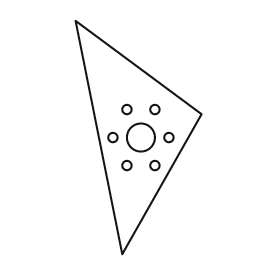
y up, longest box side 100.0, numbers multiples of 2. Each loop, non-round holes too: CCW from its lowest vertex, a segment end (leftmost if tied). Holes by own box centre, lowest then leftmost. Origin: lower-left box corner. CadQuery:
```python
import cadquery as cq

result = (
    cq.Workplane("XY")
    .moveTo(20.0, 0.0)
    .lineTo(54.0, 60.0)
    .lineTo(0.0, 100.0)
    .close()
    .moveTo(22.0, 38.0)
    .circle(2.0)
    .moveTo(34.0, 38.0)
    .circle(2.0)
    .moveTo(16.0, 50.0)
    .circle(2.0)
    .moveTo(28.0, 50.0)
    .circle(6.0)
    .moveTo(40.0, 50.0)
    .circle(2.0)
    .moveTo(22.0, 62.0)
    .circle(2.0)
    .moveTo(34.0, 62.0)
    .circle(2.0)
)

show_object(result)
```